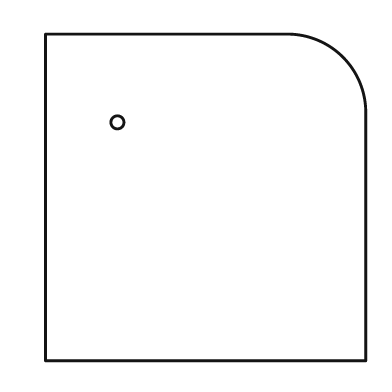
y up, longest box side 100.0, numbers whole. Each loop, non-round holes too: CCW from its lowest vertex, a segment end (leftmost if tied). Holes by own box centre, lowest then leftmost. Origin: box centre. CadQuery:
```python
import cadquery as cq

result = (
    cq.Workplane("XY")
    .moveTo(-49.0, -50.0)
    .lineTo(49.0, -50.0)
    .lineTo(49.0, 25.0)
    .threePointArc((42.0, 43.0), (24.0, 50.0))
    .lineTo(-49.0, 50.0)
    .close()
    .moveTo(-27.0, 23.0)
    .circle(2.0)
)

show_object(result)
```